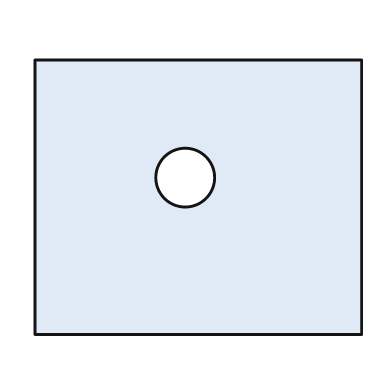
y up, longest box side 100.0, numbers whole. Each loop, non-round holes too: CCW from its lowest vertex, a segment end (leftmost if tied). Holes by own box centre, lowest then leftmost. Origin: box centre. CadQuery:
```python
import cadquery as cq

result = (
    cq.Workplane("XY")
    .moveTo(-50.0, -42.0)
    .lineTo(50.0, -42.0)
    .lineTo(50.0, 42.0)
    .lineTo(-50.0, 42.0)
    .close()
    .moveTo(-4.0, 6.0)
    .circle(9.0)
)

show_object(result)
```